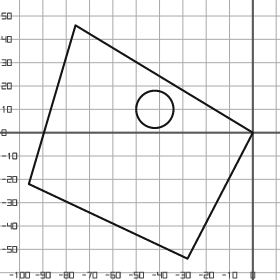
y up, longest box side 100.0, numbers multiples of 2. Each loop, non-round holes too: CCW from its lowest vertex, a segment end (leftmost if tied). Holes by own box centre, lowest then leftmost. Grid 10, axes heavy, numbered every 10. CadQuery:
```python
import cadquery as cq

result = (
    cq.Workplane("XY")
    .moveTo(-28.0, -54.0)
    .lineTo(0.0, 0.0)
    .lineTo(-76.0, 46.0)
    .lineTo(-96.0, -22.0)
    .close()
    .moveTo(-42.0, 10.0)
    .circle(8.0)
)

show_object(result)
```